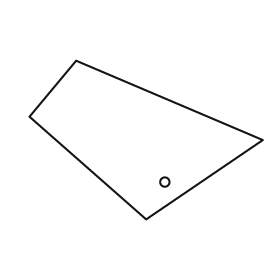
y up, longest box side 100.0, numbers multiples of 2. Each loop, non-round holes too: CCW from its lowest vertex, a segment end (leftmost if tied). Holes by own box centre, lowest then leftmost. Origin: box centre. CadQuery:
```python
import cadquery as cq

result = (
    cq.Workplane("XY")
    .moveTo(0.0, -34.0)
    .lineTo(50.0, 0.0)
    .lineTo(-30.0, 34.0)
    .lineTo(-50.0, 10.0)
    .close()
    .moveTo(8.0, -18.0)
    .circle(2.0)
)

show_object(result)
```